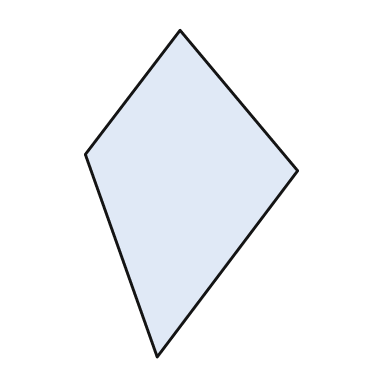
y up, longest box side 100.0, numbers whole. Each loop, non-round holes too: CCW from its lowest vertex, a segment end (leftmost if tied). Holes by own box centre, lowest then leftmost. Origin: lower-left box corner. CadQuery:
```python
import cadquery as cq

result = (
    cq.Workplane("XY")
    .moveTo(22.0, 0.0)
    .lineTo(65.0, 57.0)
    .lineTo(29.0, 100.0)
    .lineTo(0.0, 62.0)
    .close()
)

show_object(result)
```